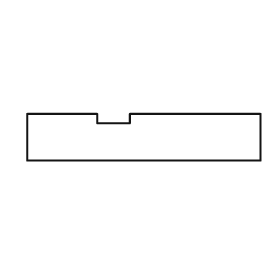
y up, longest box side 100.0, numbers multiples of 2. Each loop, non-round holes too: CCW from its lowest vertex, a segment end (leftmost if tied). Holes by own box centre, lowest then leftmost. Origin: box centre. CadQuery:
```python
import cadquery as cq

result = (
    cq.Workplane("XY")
    .moveTo(-50.0, -10.0)
    .lineTo(50.0, -10.0)
    .lineTo(50.0, 10.0)
    .lineTo(-6.0, 10.0)
    .lineTo(-6.0, 6.0)
    .lineTo(-20.0, 6.0)
    .lineTo(-20.0, 10.0)
    .lineTo(-50.0, 10.0)
    .close()
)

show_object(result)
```